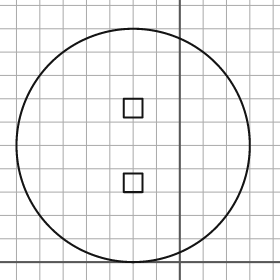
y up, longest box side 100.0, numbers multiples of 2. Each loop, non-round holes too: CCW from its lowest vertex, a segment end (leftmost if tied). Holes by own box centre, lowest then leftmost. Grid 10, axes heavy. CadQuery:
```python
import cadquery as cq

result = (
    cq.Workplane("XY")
    .moveTo(-20.0, 50.0)
    .circle(50.0)
    .moveTo(-24.0, 30.0)
    .lineTo(-16.0, 30.0)
    .lineTo(-16.0, 38.0)
    .lineTo(-24.0, 38.0)
    .close()
    .moveTo(-24.0, 62.0)
    .lineTo(-16.0, 62.0)
    .lineTo(-16.0, 70.0)
    .lineTo(-24.0, 70.0)
    .close()
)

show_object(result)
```